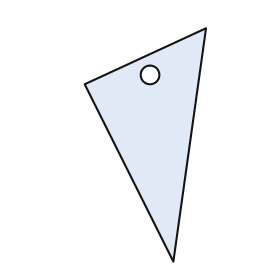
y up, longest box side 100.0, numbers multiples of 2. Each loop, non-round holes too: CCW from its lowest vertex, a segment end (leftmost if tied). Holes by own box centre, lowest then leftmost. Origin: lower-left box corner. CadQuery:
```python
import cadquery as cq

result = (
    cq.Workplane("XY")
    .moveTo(38.0, 0.0)
    .lineTo(52.0, 100.0)
    .lineTo(0.0, 76.0)
    .close()
    .moveTo(28.0, 80.0)
    .circle(4.0)
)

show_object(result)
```